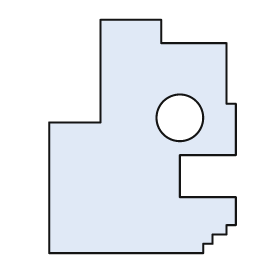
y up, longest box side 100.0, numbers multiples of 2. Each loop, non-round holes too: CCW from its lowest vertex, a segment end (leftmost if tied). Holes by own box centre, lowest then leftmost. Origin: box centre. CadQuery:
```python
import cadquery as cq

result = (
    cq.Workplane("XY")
    .moveTo(-40.0, -50.0)
    .lineTo(26.0, -50.0)
    .lineTo(26.0, -46.0)
    .lineTo(30.0, -46.0)
    .lineTo(30.0, -42.0)
    .lineTo(36.0, -42.0)
    .lineTo(36.0, -38.0)
    .lineTo(40.0, -38.0)
    .lineTo(40.0, -26.0)
    .lineTo(16.0, -26.0)
    .lineTo(16.0, -8.0)
    .lineTo(40.0, -8.0)
    .lineTo(40.0, 14.0)
    .lineTo(36.0, 14.0)
    .lineTo(36.0, 40.0)
    .lineTo(8.0, 40.0)
    .lineTo(8.0, 50.0)
    .lineTo(-18.0, 50.0)
    .lineTo(-18.0, 6.0)
    .lineTo(-40.0, 6.0)
    .close()
    .moveTo(16.0, 8.0)
    .circle(10.0)
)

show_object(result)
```